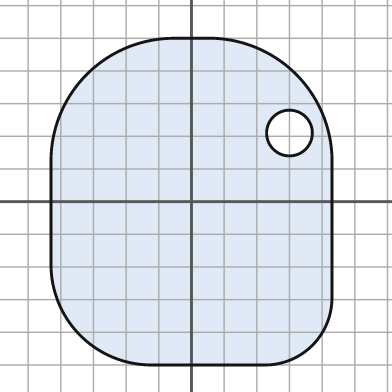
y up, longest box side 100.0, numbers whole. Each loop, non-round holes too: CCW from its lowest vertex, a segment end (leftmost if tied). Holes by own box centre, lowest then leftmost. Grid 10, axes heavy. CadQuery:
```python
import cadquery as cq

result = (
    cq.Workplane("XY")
    .moveTo(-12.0, -50.0)
    .lineTo(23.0, -50.0)
    .threePointArc((37.0, -44.0), (43.0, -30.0))
    .lineTo(43.0, 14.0)
    .threePointArc((32.0, 39.0), (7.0, 50.0))
    .lineTo(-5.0, 50.0)
    .threePointArc((-32.0, 39.0), (-43.0, 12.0))
    .lineTo(-43.0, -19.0)
    .threePointArc((-34.0, -41.0), (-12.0, -50.0))
    .close()
    .moveTo(30.0, 21.0)
    .circle(7.0)
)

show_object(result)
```